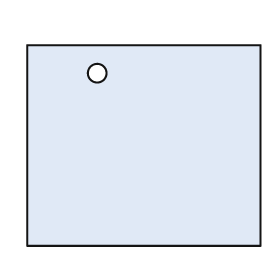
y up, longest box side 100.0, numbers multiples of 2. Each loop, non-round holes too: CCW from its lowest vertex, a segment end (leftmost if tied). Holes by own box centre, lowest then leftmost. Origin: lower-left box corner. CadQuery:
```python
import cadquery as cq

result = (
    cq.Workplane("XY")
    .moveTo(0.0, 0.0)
    .lineTo(100.0, 0.0)
    .lineTo(100.0, 86.0)
    .lineTo(0.0, 86.0)
    .close()
    .moveTo(30.0, 74.0)
    .circle(4.0)
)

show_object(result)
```